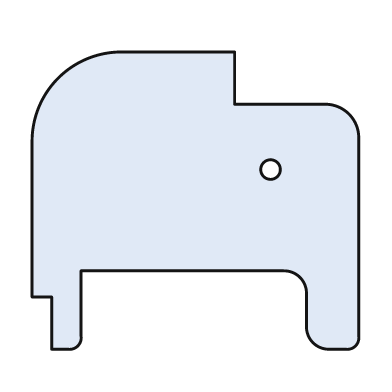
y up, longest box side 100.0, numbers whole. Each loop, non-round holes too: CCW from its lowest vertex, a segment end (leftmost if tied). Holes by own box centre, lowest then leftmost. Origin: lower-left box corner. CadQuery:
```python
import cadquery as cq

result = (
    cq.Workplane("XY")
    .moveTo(6.0, 0.0)
    .lineTo(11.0, 0.0)
    .threePointArc((14.0, 1.0), (15.0, 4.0))
    .lineTo(15.0, 24.0)
    .lineTo(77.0, 24.0)
    .threePointArc((82.0, 22.0), (84.0, 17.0))
    .lineTo(84.0, 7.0)
    .threePointArc((86.0, 2.0), (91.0, 0.0))
    .lineTo(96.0, 0.0)
    .threePointArc((99.0, 1.0), (100.0, 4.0))
    .lineTo(100.0, 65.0)
    .threePointArc((97.0, 72.0), (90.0, 75.0))
    .lineTo(62.0, 75.0)
    .lineTo(62.0, 91.0)
    .lineTo(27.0, 91.0)
    .threePointArc((8.0, 83.0), (0.0, 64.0))
    .lineTo(0.0, 16.0)
    .lineTo(6.0, 16.0)
    .close()
    .moveTo(73.0, 55.0)
    .circle(3.0)
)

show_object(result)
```